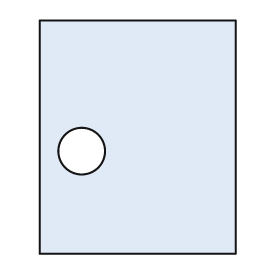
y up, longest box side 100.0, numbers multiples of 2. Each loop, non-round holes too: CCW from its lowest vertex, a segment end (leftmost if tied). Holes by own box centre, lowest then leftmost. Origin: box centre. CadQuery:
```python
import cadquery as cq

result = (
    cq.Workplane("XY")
    .moveTo(-42.0, -50.0)
    .lineTo(42.0, -50.0)
    .lineTo(42.0, 50.0)
    .lineTo(-42.0, 50.0)
    .close()
    .moveTo(-24.0, -6.0)
    .circle(10.0)
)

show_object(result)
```